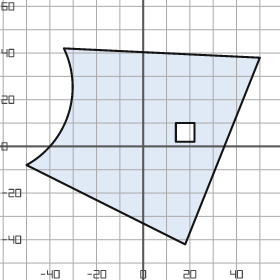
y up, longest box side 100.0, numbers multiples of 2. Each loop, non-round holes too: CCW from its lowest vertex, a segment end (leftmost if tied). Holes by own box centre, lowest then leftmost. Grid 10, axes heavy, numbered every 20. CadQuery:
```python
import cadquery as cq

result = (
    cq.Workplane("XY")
    .moveTo(18.0, -42.0)
    .lineTo(50.0, 38.0)
    .lineTo(-34.0, 42.0)
    .threePointArc((-32.0, 14.0), (-50.0, -8.0))
    .close()
    .moveTo(14.0, 2.0)
    .lineTo(22.0, 2.0)
    .lineTo(22.0, 10.0)
    .lineTo(14.0, 10.0)
    .close()
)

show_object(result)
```